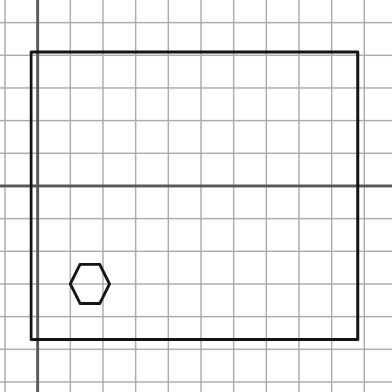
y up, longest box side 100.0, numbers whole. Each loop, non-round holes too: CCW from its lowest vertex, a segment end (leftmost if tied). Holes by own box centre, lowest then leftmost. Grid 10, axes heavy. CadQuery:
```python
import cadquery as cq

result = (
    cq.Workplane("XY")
    .moveTo(-2.0, -47.0)
    .lineTo(98.0, -47.0)
    .lineTo(98.0, 41.0)
    .lineTo(-2.0, 41.0)
    .close()
    .moveTo(13.0, -36.0)
    .lineTo(19.0, -36.0)
    .lineTo(22.0, -30.0)
    .lineTo(19.0, -24.0)
    .lineTo(13.0, -24.0)
    .lineTo(10.0, -30.0)
    .close()
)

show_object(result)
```